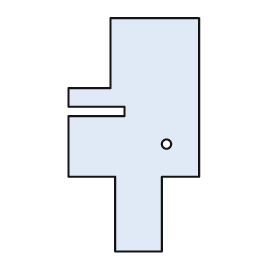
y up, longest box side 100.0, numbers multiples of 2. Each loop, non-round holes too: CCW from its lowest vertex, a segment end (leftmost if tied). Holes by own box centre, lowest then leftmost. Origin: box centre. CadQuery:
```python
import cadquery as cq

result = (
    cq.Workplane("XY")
    .moveTo(-8.0, -50.0)
    .lineTo(12.0, -50.0)
    .lineTo(12.0, -18.0)
    .lineTo(28.0, -18.0)
    .lineTo(28.0, 50.0)
    .lineTo(-10.0, 50.0)
    .lineTo(-10.0, 20.0)
    .lineTo(-28.0, 20.0)
    .lineTo(-28.0, 12.0)
    .lineTo(-4.0, 12.0)
    .lineTo(-4.0, 8.0)
    .lineTo(-28.0, 8.0)
    .lineTo(-28.0, -18.0)
    .lineTo(-8.0, -18.0)
    .close()
    .moveTo(14.0, -4.0)
    .circle(2.0)
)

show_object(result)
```